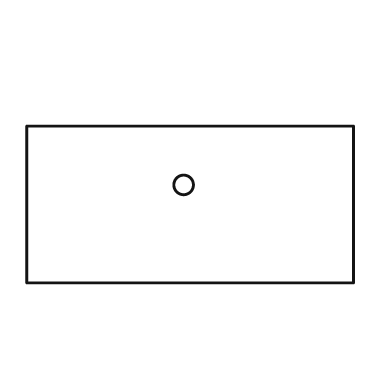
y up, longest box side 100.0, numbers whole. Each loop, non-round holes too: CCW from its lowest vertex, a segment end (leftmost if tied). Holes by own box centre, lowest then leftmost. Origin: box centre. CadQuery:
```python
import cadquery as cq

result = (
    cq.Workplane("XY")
    .moveTo(-50.0, -24.0)
    .lineTo(50.0, -24.0)
    .lineTo(50.0, 24.0)
    .lineTo(-50.0, 24.0)
    .close()
    .moveTo(-2.0, 6.0)
    .circle(3.0)
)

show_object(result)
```